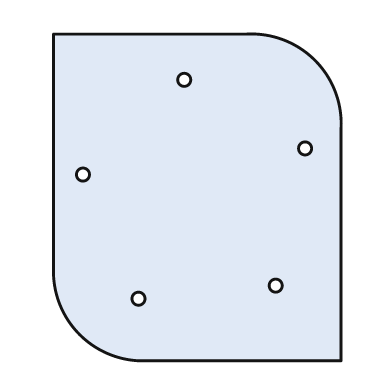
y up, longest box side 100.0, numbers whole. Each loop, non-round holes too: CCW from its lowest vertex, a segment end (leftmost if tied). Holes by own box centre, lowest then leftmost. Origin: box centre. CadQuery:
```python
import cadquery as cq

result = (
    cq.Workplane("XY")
    .moveTo(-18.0, -50.0)
    .lineTo(44.0, -50.0)
    .lineTo(44.0, 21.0)
    .threePointArc((36.0, 42.0), (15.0, 50.0))
    .lineTo(-44.0, 50.0)
    .lineTo(-44.0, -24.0)
    .threePointArc((-36.0, -42.0), (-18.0, -50.0))
    .close()
    .moveTo(-18.0, -31.0)
    .circle(2.0)
    .moveTo(24.0, -27.0)
    .circle(2.0)
    .moveTo(-35.0, 7.0)
    .circle(2.0)
    .moveTo(33.0, 15.0)
    .circle(2.0)
    .moveTo(-4.0, 36.0)
    .circle(2.0)
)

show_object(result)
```